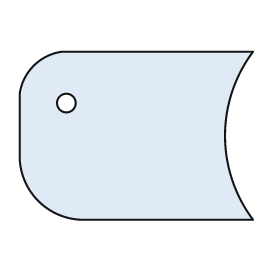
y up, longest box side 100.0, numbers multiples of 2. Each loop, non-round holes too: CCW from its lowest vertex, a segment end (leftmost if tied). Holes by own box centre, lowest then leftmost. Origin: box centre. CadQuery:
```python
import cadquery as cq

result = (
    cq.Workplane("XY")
    .moveTo(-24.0, -36.0)
    .lineTo(50.0, -36.0)
    .threePointArc((38.0, 0.0), (50.0, 36.0))
    .lineTo(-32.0, 36.0)
    .threePointArc((-44.0, 30.0), (-50.0, 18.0))
    .lineTo(-50.0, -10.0)
    .threePointArc((-42.0, -28.0), (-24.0, -36.0))
    .close()
    .moveTo(-30.0, 14.0)
    .circle(4.0)
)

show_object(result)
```